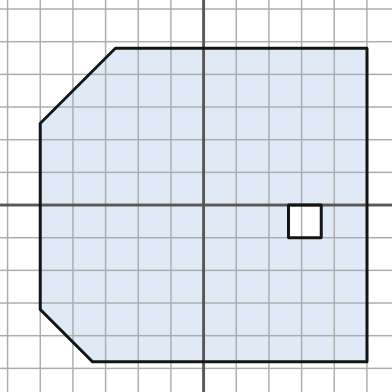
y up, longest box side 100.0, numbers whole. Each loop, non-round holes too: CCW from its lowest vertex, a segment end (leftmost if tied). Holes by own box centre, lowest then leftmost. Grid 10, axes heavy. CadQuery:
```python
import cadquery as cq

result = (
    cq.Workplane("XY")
    .moveTo(-34.0, -48.0)
    .lineTo(50.0, -48.0)
    .lineTo(50.0, 48.0)
    .lineTo(-27.0, 48.0)
    .lineTo(-50.0, 25.0)
    .lineTo(-50.0, -32.0)
    .close()
    .moveTo(26.0, -10.0)
    .lineTo(36.0, -10.0)
    .lineTo(36.0, 0.0)
    .lineTo(26.0, 0.0)
    .close()
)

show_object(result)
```